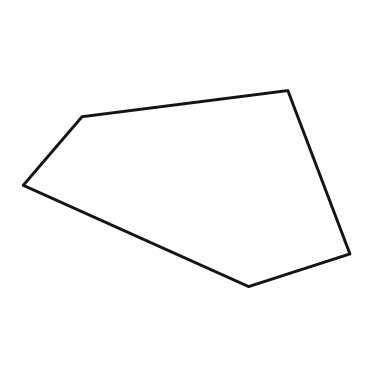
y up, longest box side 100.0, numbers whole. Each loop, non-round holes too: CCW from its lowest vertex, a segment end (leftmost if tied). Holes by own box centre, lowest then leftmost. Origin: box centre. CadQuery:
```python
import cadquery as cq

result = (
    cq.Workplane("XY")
    .moveTo(19.0, -30.0)
    .lineTo(50.0, -20.0)
    .lineTo(31.0, 30.0)
    .lineTo(-32.0, 22.0)
    .lineTo(-50.0, 1.0)
    .close()
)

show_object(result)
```